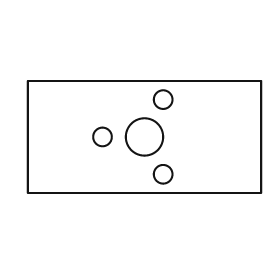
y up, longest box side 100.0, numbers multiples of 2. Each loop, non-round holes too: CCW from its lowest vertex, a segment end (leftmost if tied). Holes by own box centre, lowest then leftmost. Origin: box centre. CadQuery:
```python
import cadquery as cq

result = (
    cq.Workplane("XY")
    .moveTo(-50.0, -24.0)
    .lineTo(50.0, -24.0)
    .lineTo(50.0, 24.0)
    .lineTo(-50.0, 24.0)
    .close()
    .moveTo(8.0, -16.0)
    .circle(4.0)
    .moveTo(-18.0, 0.0)
    .circle(4.0)
    .moveTo(0.0, 0.0)
    .circle(8.0)
    .moveTo(8.0, 16.0)
    .circle(4.0)
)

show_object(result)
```